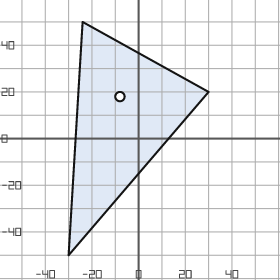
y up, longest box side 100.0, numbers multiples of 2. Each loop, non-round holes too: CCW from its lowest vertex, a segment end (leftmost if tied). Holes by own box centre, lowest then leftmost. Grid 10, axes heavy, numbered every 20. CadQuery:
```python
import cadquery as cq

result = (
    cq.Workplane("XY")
    .moveTo(-30.0, -50.0)
    .lineTo(30.0, 20.0)
    .lineTo(-24.0, 50.0)
    .close()
    .moveTo(-8.0, 18.0)
    .circle(2.0)
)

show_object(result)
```